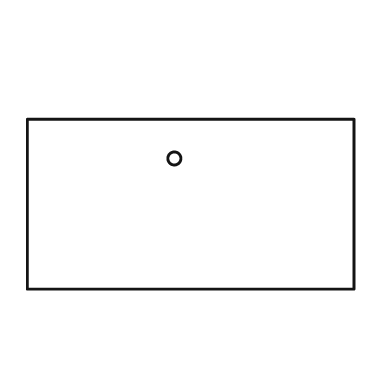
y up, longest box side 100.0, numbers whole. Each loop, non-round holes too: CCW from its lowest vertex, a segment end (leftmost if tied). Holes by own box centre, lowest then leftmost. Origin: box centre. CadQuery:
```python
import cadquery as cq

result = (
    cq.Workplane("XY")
    .moveTo(-50.0, -26.0)
    .lineTo(50.0, -26.0)
    .lineTo(50.0, 26.0)
    .lineTo(-50.0, 26.0)
    .close()
    .moveTo(-5.0, 14.0)
    .circle(2.0)
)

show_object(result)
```